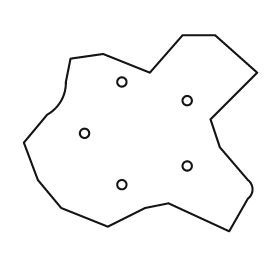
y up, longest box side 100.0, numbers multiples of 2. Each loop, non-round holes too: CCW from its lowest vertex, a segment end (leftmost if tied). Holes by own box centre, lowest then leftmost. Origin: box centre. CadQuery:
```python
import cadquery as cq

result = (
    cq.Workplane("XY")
    .moveTo(38.0, -42.0)
    .lineTo(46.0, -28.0)
    .threePointArc((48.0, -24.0), (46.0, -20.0))
    .lineTo(34.0, -6.0)
    .lineTo(30.0, 6.0)
    .lineTo(50.0, 26.0)
    .lineTo(32.0, 42.0)
    .lineTo(18.0, 42.0)
    .lineTo(4.0, 26.0)
    .lineTo(-16.0, 34.0)
    .lineTo(-30.0, 32.0)
    .lineTo(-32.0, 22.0)
    .threePointArc((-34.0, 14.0), (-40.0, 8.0))
    .lineTo(-50.0, -4.0)
    .lineTo(-44.0, -20.0)
    .lineTo(-34.0, -32.0)
    .lineTo(-14.0, -40.0)
    .lineTo(2.0, -32.0)
    .lineTo(12.0, -30.0)
    .close()
    .moveTo(-8.0, -22.0)
    .circle(2.0)
    .moveTo(20.0, -14.0)
    .circle(2.0)
    .moveTo(-24.0, 0.0)
    .circle(2.0)
    .moveTo(20.0, 14.0)
    .circle(2.0)
    .moveTo(-8.0, 22.0)
    .circle(2.0)
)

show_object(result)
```